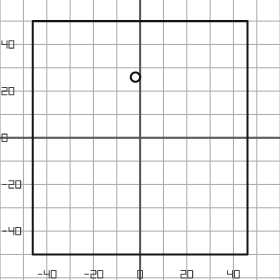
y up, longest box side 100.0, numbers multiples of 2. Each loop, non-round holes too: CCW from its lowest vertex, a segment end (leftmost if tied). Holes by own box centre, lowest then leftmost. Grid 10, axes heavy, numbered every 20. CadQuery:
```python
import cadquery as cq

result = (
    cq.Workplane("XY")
    .moveTo(-46.0, -50.0)
    .lineTo(46.0, -50.0)
    .lineTo(46.0, 50.0)
    .lineTo(-46.0, 50.0)
    .close()
    .moveTo(-2.0, 26.0)
    .circle(2.0)
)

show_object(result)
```